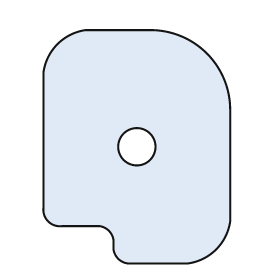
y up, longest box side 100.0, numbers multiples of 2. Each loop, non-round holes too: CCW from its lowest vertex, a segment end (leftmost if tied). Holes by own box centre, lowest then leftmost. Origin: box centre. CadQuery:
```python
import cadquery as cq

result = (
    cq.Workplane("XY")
    .moveTo(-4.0, -50.0)
    .lineTo(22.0, -50.0)
    .threePointArc((34.0, -44.0), (40.0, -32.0))
    .lineTo(40.0, 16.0)
    .threePointArc((30.0, 40.0), (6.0, 50.0))
    .lineTo(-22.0, 50.0)
    .threePointArc((-34.0, 44.0), (-40.0, 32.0))
    .lineTo(-40.0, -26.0)
    .threePointArc((-38.0, -32.0), (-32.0, -34.0))
    .lineTo(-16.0, -34.0)
    .threePointArc((-12.0, -36.0), (-10.0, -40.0))
    .lineTo(-10.0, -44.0)
    .threePointArc((-8.0, -48.0), (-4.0, -50.0))
    .close()
    .moveTo(0.0, 0.0)
    .circle(8.0)
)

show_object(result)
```